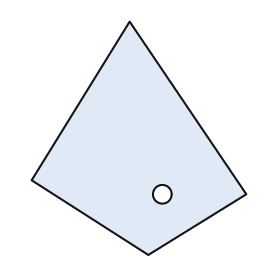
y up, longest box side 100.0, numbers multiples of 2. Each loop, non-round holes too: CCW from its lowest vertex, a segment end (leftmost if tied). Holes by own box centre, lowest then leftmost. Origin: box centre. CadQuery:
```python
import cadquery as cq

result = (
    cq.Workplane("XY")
    .moveTo(4.0, -50.0)
    .lineTo(46.0, -24.0)
    .lineTo(-4.0, 50.0)
    .lineTo(-46.0, -18.0)
    .close()
    .moveTo(10.0, -24.0)
    .circle(4.0)
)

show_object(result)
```